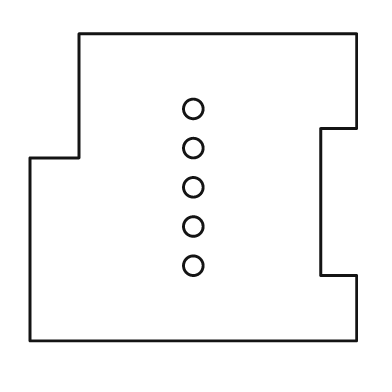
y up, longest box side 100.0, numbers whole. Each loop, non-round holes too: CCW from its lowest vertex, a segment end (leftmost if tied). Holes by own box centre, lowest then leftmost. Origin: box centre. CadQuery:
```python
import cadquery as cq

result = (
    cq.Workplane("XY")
    .moveTo(-50.0, -47.0)
    .lineTo(50.0, -47.0)
    .lineTo(50.0, -27.0)
    .lineTo(39.0, -27.0)
    .lineTo(39.0, 18.0)
    .lineTo(50.0, 18.0)
    .lineTo(50.0, 47.0)
    .lineTo(-35.0, 47.0)
    .lineTo(-35.0, 9.0)
    .lineTo(-50.0, 9.0)
    .close()
    .moveTo(0.0, -24.0)
    .circle(3.0)
    .moveTo(0.0, -12.0)
    .circle(3.0)
    .moveTo(0.0, 0.0)
    .circle(3.0)
    .moveTo(0.0, 12.0)
    .circle(3.0)
    .moveTo(0.0, 24.0)
    .circle(3.0)
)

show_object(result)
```